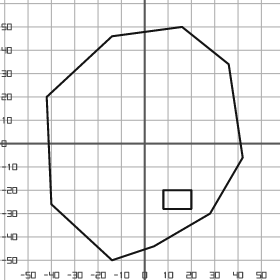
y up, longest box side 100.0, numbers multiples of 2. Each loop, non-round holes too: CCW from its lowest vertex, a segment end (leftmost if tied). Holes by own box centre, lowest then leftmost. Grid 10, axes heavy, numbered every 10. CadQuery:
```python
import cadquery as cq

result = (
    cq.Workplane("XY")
    .moveTo(-14.0, -50.0)
    .lineTo(4.0, -44.0)
    .lineTo(28.0, -30.0)
    .lineTo(42.0, -6.0)
    .lineTo(36.0, 34.0)
    .lineTo(16.0, 50.0)
    .lineTo(-14.0, 46.0)
    .lineTo(-42.0, 20.0)
    .lineTo(-40.0, -26.0)
    .close()
    .moveTo(8.0, -28.0)
    .lineTo(20.0, -28.0)
    .lineTo(20.0, -20.0)
    .lineTo(8.0, -20.0)
    .close()
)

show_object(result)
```